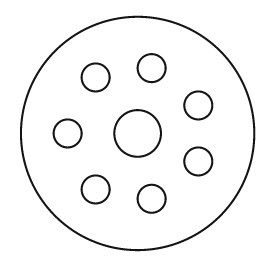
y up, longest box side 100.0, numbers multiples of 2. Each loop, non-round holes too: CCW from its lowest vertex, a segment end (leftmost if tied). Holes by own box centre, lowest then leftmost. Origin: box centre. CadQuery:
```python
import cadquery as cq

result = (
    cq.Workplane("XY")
    .moveTo(0.0, 0.0)
    .circle(50.0)
    .moveTo(6.0, -28.0)
    .circle(6.0)
    .moveTo(-18.0, -24.0)
    .circle(6.0)
    .moveTo(26.0, -12.0)
    .circle(6.0)
    .moveTo(-30.0, 0.0)
    .circle(6.0)
    .moveTo(0.0, 0.0)
    .circle(10.0)
    .moveTo(26.0, 12.0)
    .circle(6.0)
    .moveTo(-18.0, 24.0)
    .circle(6.0)
    .moveTo(6.0, 28.0)
    .circle(6.0)
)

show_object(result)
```